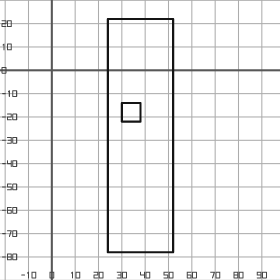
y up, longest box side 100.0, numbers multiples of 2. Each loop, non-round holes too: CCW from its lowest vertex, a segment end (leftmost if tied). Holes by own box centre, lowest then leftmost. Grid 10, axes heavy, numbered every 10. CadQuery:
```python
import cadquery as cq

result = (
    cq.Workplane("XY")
    .moveTo(24.0, -78.0)
    .lineTo(52.0, -78.0)
    .lineTo(52.0, 22.0)
    .lineTo(24.0, 22.0)
    .close()
    .moveTo(30.0, -22.0)
    .lineTo(38.0, -22.0)
    .lineTo(38.0, -14.0)
    .lineTo(30.0, -14.0)
    .close()
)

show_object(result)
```